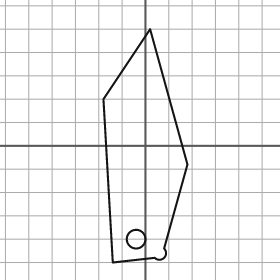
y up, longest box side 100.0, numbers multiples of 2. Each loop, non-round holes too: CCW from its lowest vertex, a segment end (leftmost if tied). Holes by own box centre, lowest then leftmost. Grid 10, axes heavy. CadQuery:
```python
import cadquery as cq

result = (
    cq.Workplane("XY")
    .moveTo(-14.0, -50.0)
    .lineTo(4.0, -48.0)
    .threePointArc((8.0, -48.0), (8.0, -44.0))
    .lineTo(18.0, -8.0)
    .lineTo(2.0, 50.0)
    .lineTo(-18.0, 20.0)
    .close()
    .moveTo(-4.0, -40.0)
    .circle(4.0)
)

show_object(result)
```